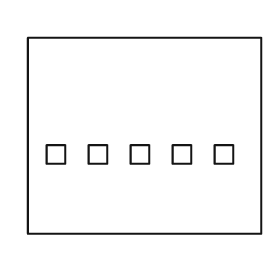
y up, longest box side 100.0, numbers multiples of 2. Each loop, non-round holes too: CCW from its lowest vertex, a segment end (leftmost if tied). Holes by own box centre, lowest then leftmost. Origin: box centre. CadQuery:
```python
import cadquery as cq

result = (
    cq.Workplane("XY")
    .moveTo(-50.0, -42.0)
    .lineTo(50.0, -42.0)
    .lineTo(50.0, 42.0)
    .lineTo(-50.0, 42.0)
    .close()
    .moveTo(-42.0, -12.0)
    .lineTo(-34.0, -12.0)
    .lineTo(-34.0, -4.0)
    .lineTo(-42.0, -4.0)
    .close()
    .moveTo(-24.0, -12.0)
    .lineTo(-16.0, -12.0)
    .lineTo(-16.0, -4.0)
    .lineTo(-24.0, -4.0)
    .close()
    .moveTo(-6.0, -12.0)
    .lineTo(2.0, -12.0)
    .lineTo(2.0, -4.0)
    .lineTo(-6.0, -4.0)
    .close()
    .moveTo(12.0, -12.0)
    .lineTo(20.0, -12.0)
    .lineTo(20.0, -4.0)
    .lineTo(12.0, -4.0)
    .close()
    .moveTo(30.0, -12.0)
    .lineTo(38.0, -12.0)
    .lineTo(38.0, -4.0)
    .lineTo(30.0, -4.0)
    .close()
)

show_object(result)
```